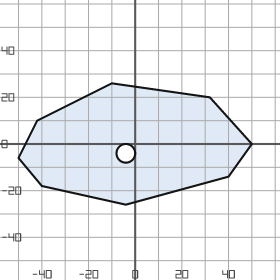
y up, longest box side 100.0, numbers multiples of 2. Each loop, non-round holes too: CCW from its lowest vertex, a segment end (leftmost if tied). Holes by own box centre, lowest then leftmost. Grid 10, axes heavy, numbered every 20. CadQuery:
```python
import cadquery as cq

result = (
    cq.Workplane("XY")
    .moveTo(-4.0, -26.0)
    .lineTo(40.0, -14.0)
    .lineTo(50.0, 0.0)
    .lineTo(32.0, 20.0)
    .lineTo(-10.0, 26.0)
    .lineTo(-42.0, 10.0)
    .lineTo(-50.0, -6.0)
    .lineTo(-40.0, -18.0)
    .close()
    .moveTo(-4.0, -4.0)
    .circle(4.0)
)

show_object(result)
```